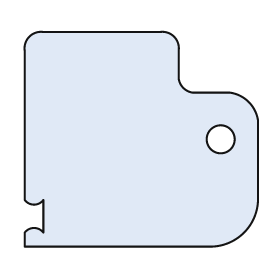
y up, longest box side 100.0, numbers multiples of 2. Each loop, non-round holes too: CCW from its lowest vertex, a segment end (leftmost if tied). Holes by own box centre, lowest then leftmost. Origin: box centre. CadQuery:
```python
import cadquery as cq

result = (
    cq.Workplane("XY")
    .moveTo(-50.0, -46.0)
    .lineTo(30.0, -46.0)
    .threePointArc((44.0, -40.0), (50.0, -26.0))
    .lineTo(50.0, 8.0)
    .threePointArc((46.0, 16.0), (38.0, 20.0))
    .lineTo(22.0, 20.0)
    .threePointArc((18.0, 22.0), (16.0, 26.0))
    .lineTo(16.0, 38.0)
    .threePointArc((14.0, 44.0), (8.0, 46.0))
    .lineTo(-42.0, 46.0)
    .threePointArc((-48.0, 44.0), (-50.0, 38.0))
    .lineTo(-50.0, -26.0)
    .threePointArc((-46.0, -28.0), (-42.0, -26.0))
    .lineTo(-42.0, -40.0)
    .threePointArc((-46.0, -38.0), (-50.0, -40.0))
    .close()
    .moveTo(34.0, 0.0)
    .circle(6.0)
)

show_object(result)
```